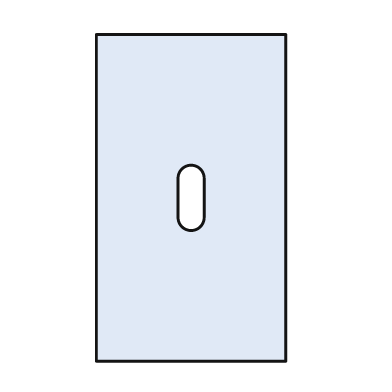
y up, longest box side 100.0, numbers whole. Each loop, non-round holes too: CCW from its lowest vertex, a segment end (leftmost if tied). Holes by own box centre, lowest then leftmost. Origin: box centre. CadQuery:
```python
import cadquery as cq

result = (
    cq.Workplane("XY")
    .moveTo(-29.0, -50.0)
    .lineTo(29.0, -50.0)
    .lineTo(29.0, 50.0)
    .lineTo(-29.0, 50.0)
    .close()
    .moveTo(-4.0, -6.0)
    .threePointArc((0.0, -10.0), (4.0, -6.0))
    .lineTo(4.0, 6.0)
    .threePointArc((0.0, 10.0), (-4.0, 6.0))
    .close()
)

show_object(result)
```